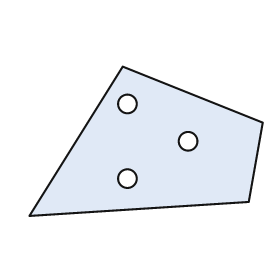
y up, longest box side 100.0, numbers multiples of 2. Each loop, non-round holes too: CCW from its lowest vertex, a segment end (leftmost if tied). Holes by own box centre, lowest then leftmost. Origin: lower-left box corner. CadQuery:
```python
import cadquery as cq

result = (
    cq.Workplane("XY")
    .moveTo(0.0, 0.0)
    .lineTo(94.0, 6.0)
    .lineTo(100.0, 40.0)
    .lineTo(40.0, 64.0)
    .close()
    .moveTo(42.0, 16.0)
    .circle(4.0)
    .moveTo(68.0, 32.0)
    .circle(4.0)
    .moveTo(42.0, 48.0)
    .circle(4.0)
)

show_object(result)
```